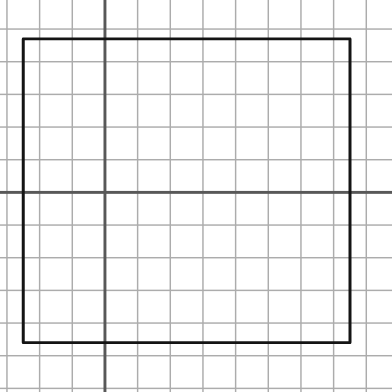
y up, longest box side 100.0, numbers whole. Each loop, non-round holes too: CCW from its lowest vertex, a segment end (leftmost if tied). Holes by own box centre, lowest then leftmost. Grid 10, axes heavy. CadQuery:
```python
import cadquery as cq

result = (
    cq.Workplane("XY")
    .moveTo(-25.0, -46.0)
    .lineTo(75.0, -46.0)
    .lineTo(75.0, 47.0)
    .lineTo(-25.0, 47.0)
    .close()
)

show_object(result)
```